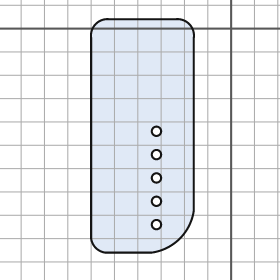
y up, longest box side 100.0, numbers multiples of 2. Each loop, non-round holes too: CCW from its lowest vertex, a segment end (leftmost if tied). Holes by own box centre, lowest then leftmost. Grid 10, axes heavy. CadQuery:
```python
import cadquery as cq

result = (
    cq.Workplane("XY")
    .moveTo(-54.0, -96.0)
    .lineTo(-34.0, -96.0)
    .threePointArc((-22.0, -90.0), (-16.0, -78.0))
    .lineTo(-16.0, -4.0)
    .threePointArc((-18.0, 2.0), (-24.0, 4.0))
    .lineTo(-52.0, 4.0)
    .threePointArc((-58.0, 2.0), (-60.0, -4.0))
    .lineTo(-60.0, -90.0)
    .threePointArc((-58.0, -94.0), (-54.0, -96.0))
    .close()
    .moveTo(-32.0, -84.0)
    .circle(2.0)
    .moveTo(-32.0, -74.0)
    .circle(2.0)
    .moveTo(-32.0, -64.0)
    .circle(2.0)
    .moveTo(-32.0, -54.0)
    .circle(2.0)
    .moveTo(-32.0, -44.0)
    .circle(2.0)
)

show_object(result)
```